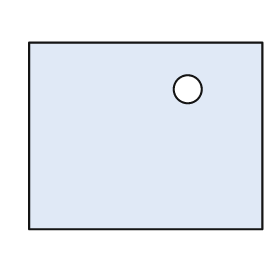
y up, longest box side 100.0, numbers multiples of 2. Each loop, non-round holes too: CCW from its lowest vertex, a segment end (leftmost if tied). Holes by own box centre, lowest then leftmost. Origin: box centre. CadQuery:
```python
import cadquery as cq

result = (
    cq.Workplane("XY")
    .moveTo(-50.0, -40.0)
    .lineTo(50.0, -40.0)
    .lineTo(50.0, 40.0)
    .lineTo(-50.0, 40.0)
    .close()
    .moveTo(18.0, 20.0)
    .circle(6.0)
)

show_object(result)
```